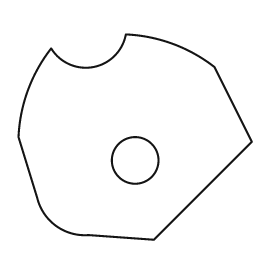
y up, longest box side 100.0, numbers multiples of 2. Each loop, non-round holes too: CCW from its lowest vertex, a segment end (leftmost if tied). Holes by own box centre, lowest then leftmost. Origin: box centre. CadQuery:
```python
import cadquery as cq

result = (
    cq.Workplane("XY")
    .moveTo(8.0, -44.0)
    .lineTo(50.0, -2.0)
    .lineTo(34.0, 30.0)
    .threePointArc((16.0, 40.0), (-4.0, 44.0))
    .threePointArc((-18.0, 30.0), (-36.0, 38.0))
    .threePointArc((-46.0, 20.0), (-50.0, 0.0))
    .lineTo(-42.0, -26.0)
    .threePointArc((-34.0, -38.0), (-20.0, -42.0))
    .close()
    .moveTo(0.0, -10.0)
    .circle(10.0)
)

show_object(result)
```